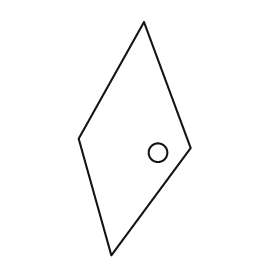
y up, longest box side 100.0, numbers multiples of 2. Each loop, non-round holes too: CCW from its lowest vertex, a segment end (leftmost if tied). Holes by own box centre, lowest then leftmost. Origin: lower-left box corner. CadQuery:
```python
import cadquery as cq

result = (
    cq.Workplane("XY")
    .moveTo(14.0, 0.0)
    .lineTo(48.0, 46.0)
    .lineTo(28.0, 100.0)
    .lineTo(0.0, 50.0)
    .close()
    .moveTo(34.0, 44.0)
    .circle(4.0)
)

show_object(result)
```